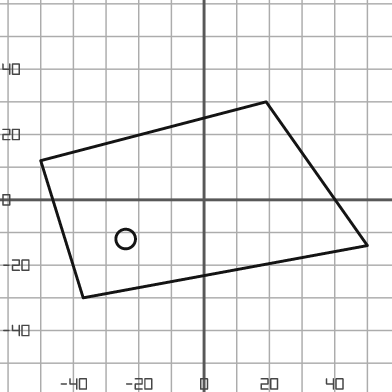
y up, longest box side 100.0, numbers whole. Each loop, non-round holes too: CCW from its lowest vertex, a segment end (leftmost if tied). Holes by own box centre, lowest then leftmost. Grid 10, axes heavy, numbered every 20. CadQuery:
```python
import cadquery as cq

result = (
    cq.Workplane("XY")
    .moveTo(-37.0, -30.0)
    .lineTo(50.0, -14.0)
    .lineTo(19.0, 30.0)
    .lineTo(-50.0, 12.0)
    .close()
    .moveTo(-24.0, -12.0)
    .circle(3.0)
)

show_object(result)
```